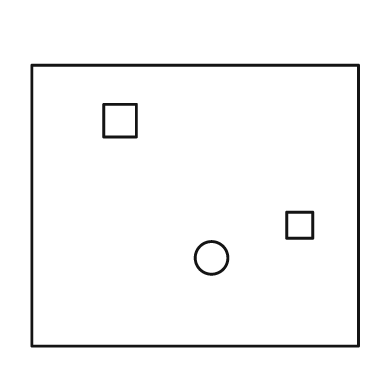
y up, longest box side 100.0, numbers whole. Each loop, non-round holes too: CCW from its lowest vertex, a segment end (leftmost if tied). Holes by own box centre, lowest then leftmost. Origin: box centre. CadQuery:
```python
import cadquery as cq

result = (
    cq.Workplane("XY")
    .moveTo(-50.0, -43.0)
    .lineTo(50.0, -43.0)
    .lineTo(50.0, 43.0)
    .lineTo(-50.0, 43.0)
    .close()
    .moveTo(5.0, -16.0)
    .circle(5.0)
    .moveTo(28.0, -10.0)
    .lineTo(36.0, -10.0)
    .lineTo(36.0, -2.0)
    .lineTo(28.0, -2.0)
    .close()
    .moveTo(-28.0, 21.0)
    .lineTo(-18.0, 21.0)
    .lineTo(-18.0, 31.0)
    .lineTo(-28.0, 31.0)
    .close()
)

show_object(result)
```